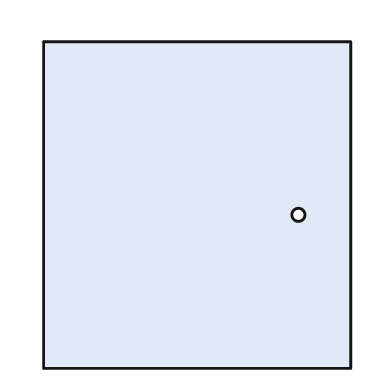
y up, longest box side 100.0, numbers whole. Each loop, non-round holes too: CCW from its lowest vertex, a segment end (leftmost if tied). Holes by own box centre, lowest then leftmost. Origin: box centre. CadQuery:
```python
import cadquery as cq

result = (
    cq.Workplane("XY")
    .moveTo(-47.0, -50.0)
    .lineTo(47.0, -50.0)
    .lineTo(47.0, 50.0)
    .lineTo(-47.0, 50.0)
    .close()
    .moveTo(31.0, -3.0)
    .circle(2.0)
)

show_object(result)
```